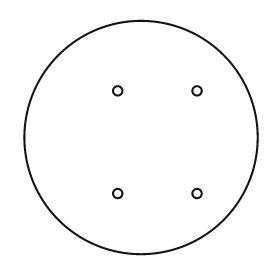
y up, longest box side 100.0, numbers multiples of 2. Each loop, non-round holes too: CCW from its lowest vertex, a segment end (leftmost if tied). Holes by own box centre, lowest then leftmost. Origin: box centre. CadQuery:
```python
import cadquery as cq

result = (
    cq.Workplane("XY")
    .moveTo(0.0, 0.0)
    .circle(50.0)
    .moveTo(-10.0, -24.0)
    .circle(2.0)
    .moveTo(24.0, -24.0)
    .circle(2.0)
    .moveTo(-10.0, 20.0)
    .circle(2.0)
    .moveTo(24.0, 20.0)
    .circle(2.0)
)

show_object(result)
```